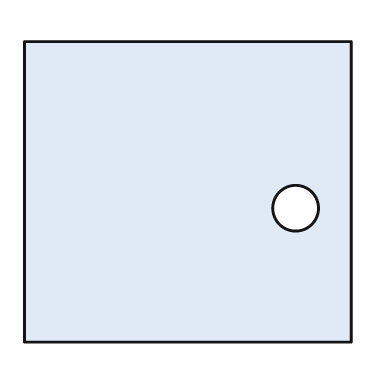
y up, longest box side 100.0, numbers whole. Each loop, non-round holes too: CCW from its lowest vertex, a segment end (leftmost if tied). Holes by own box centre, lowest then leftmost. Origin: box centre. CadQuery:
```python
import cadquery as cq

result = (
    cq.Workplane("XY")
    .moveTo(-50.0, -46.0)
    .lineTo(50.0, -46.0)
    .lineTo(50.0, 46.0)
    .lineTo(-50.0, 46.0)
    .close()
    .moveTo(33.0, -5.0)
    .circle(7.0)
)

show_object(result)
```